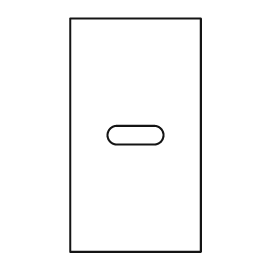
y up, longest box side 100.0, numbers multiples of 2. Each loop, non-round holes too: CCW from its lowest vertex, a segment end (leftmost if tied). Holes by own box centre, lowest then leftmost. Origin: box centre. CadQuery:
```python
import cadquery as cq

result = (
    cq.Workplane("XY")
    .moveTo(-28.0, -50.0)
    .lineTo(28.0, -50.0)
    .lineTo(28.0, 50.0)
    .lineTo(-28.0, 50.0)
    .close()
    .moveTo(-8.0, -4.0)
    .lineTo(8.0, -4.0)
    .threePointArc((12.0, 0.0), (8.0, 4.0))
    .lineTo(-8.0, 4.0)
    .threePointArc((-12.0, 0.0), (-8.0, -4.0))
    .close()
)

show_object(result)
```